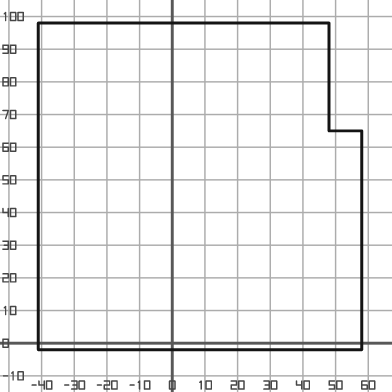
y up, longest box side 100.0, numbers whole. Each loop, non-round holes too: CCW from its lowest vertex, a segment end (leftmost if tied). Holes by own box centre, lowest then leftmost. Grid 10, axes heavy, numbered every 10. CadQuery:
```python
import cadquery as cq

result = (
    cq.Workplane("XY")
    .moveTo(-41.0, -2.0)
    .lineTo(58.0, -2.0)
    .lineTo(58.0, 65.0)
    .lineTo(48.0, 65.0)
    .lineTo(48.0, 98.0)
    .lineTo(-41.0, 98.0)
    .close()
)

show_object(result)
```